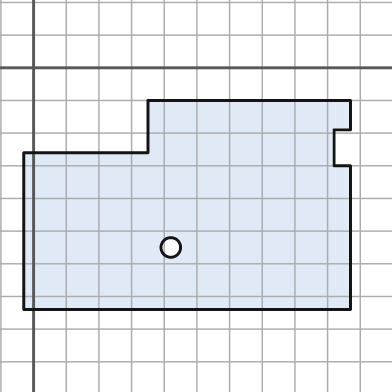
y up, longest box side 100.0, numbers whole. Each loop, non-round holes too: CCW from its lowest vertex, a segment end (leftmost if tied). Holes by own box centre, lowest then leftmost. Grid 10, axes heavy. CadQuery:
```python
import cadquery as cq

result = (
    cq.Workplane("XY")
    .moveTo(-3.0, -74.0)
    .lineTo(97.0, -74.0)
    .lineTo(97.0, -30.0)
    .lineTo(92.0, -30.0)
    .lineTo(92.0, -19.0)
    .lineTo(97.0, -19.0)
    .lineTo(97.0, -10.0)
    .lineTo(35.0, -10.0)
    .lineTo(35.0, -26.0)
    .lineTo(-3.0, -26.0)
    .close()
    .moveTo(42.0, -55.0)
    .circle(3.0)
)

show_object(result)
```